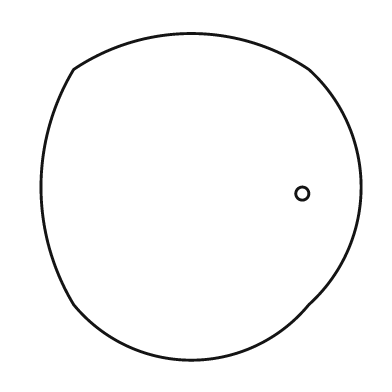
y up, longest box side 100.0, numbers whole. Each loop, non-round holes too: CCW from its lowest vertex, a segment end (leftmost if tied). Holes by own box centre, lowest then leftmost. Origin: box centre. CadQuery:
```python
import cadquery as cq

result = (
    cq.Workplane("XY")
    .moveTo(-39.0, -33.0)
    .threePointArc((-3.0, -50.0), (33.0, -33.0))
    .threePointArc((49.0, 3.0), (33.0, 39.0))
    .threePointArc((-3.0, 50.0), (-39.0, 39.0))
    .threePointArc((-49.0, 3.0), (-39.0, -33.0))
    .close()
    .moveTo(31.0, 1.0)
    .circle(2.0)
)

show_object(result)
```